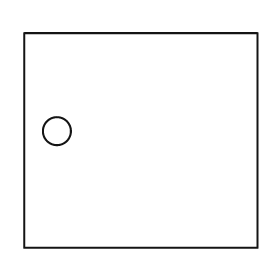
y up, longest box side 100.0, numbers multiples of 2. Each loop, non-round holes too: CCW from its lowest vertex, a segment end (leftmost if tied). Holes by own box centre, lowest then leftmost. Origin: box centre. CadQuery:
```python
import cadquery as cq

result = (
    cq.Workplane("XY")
    .moveTo(-50.0, -46.0)
    .lineTo(50.0, -46.0)
    .lineTo(50.0, 46.0)
    .lineTo(-50.0, 46.0)
    .close()
    .moveTo(-36.0, 4.0)
    .circle(6.0)
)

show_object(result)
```